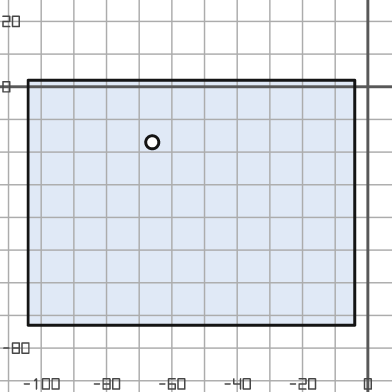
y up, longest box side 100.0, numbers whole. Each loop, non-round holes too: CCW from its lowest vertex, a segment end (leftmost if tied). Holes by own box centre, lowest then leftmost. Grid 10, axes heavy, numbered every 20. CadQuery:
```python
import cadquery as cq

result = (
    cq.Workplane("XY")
    .moveTo(-104.0, -73.0)
    .lineTo(-4.0, -73.0)
    .lineTo(-4.0, 2.0)
    .lineTo(-104.0, 2.0)
    .close()
    .moveTo(-66.0, -17.0)
    .circle(2.0)
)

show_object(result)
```